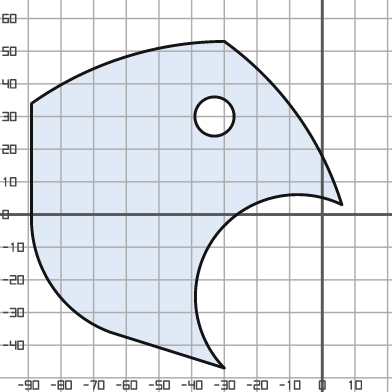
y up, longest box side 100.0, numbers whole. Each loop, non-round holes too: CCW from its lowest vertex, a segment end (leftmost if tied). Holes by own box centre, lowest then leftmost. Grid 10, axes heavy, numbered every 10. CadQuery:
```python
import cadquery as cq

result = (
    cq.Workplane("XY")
    .moveTo(-30.0, -47.0)
    .threePointArc((-33.0, -7.0), (6.0, 3.0))
    .threePointArc((-8.0, 31.0), (-30.0, 53.0))
    .threePointArc((-61.0, 48.0), (-89.0, 34.0))
    .lineTo(-89.0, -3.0)
    .threePointArc((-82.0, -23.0), (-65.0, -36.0))
    .close()
    .moveTo(-33.0, 30.0)
    .circle(6.0)
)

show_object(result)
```